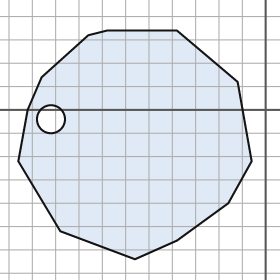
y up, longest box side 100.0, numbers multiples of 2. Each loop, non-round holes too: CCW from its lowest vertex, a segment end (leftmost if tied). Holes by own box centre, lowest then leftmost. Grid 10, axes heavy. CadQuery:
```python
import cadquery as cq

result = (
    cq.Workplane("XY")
    .moveTo(-56.0, -64.0)
    .lineTo(-38.0, -56.0)
    .lineTo(-16.0, -40.0)
    .lineTo(-6.0, -22.0)
    .lineTo(-12.0, 12.0)
    .lineTo(-38.0, 34.0)
    .lineTo(-68.0, 34.0)
    .lineTo(-76.0, 32.0)
    .lineTo(-96.0, 14.0)
    .lineTo(-102.0, 0.0)
    .lineTo(-106.0, -22.0)
    .lineTo(-88.0, -52.0)
    .close()
    .moveTo(-92.0, -4.0)
    .circle(6.0)
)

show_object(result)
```